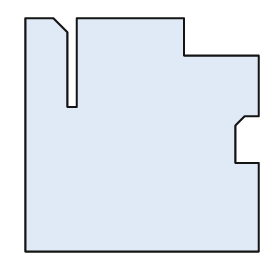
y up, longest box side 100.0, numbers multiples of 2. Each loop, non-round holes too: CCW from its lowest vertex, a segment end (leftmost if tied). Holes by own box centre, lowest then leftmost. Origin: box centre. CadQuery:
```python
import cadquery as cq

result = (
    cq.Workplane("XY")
    .moveTo(-50.0, -50.0)
    .lineTo(50.0, -50.0)
    .lineTo(50.0, -12.0)
    .lineTo(40.0, -12.0)
    .lineTo(40.0, 4.0)
    .lineTo(44.0, 8.0)
    .lineTo(50.0, 8.0)
    .lineTo(50.0, 34.0)
    .lineTo(18.0, 34.0)
    .lineTo(18.0, 50.0)
    .lineTo(-28.0, 50.0)
    .lineTo(-28.0, 12.0)
    .lineTo(-32.0, 12.0)
    .lineTo(-32.0, 44.0)
    .lineTo(-38.0, 50.0)
    .lineTo(-50.0, 50.0)
    .close()
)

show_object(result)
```